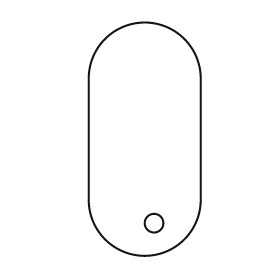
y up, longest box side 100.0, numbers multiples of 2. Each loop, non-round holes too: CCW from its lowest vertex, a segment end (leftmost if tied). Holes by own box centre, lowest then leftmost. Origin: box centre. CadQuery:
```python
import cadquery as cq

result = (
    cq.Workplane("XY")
    .moveTo(-24.0, -26.0)
    .threePointArc((0.0, -50.0), (24.0, -26.0))
    .lineTo(24.0, 26.0)
    .threePointArc((0.0, 50.0), (-24.0, 26.0))
    .close()
    .moveTo(4.0, -36.0)
    .circle(4.0)
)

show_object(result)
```